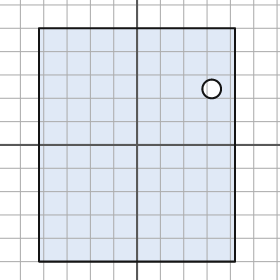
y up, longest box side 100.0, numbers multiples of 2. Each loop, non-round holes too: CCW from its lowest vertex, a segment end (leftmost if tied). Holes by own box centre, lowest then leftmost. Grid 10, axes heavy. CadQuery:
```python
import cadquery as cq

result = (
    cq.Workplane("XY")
    .moveTo(-42.0, -50.0)
    .lineTo(42.0, -50.0)
    .lineTo(42.0, 50.0)
    .lineTo(-42.0, 50.0)
    .close()
    .moveTo(32.0, 24.0)
    .circle(4.0)
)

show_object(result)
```